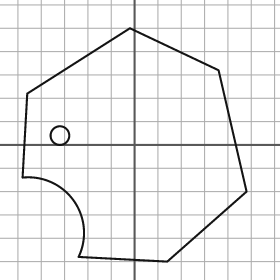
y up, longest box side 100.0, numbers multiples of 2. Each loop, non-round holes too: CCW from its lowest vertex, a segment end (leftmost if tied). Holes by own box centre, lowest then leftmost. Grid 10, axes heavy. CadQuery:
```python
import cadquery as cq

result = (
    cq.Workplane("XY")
    .moveTo(14.0, -50.0)
    .lineTo(48.0, -20.0)
    .lineTo(36.0, 32.0)
    .lineTo(-2.0, 50.0)
    .lineTo(-46.0, 22.0)
    .lineTo(-48.0, -14.0)
    .threePointArc((-26.0, -24.0), (-24.0, -48.0))
    .close()
    .moveTo(-32.0, 4.0)
    .circle(4.0)
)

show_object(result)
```